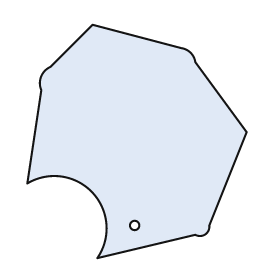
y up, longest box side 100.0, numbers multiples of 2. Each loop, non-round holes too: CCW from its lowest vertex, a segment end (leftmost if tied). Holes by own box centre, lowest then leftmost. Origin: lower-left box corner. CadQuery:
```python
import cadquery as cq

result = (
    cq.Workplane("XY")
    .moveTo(30.0, 0.0)
    .lineTo(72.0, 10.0)
    .threePointArc((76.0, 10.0), (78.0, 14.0))
    .lineTo(94.0, 54.0)
    .lineTo(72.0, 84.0)
    .threePointArc((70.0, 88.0), (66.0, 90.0))
    .lineTo(28.0, 100.0)
    .lineTo(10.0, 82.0)
    .threePointArc((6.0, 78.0), (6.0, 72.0))
    .lineTo(0.0, 32.0)
    .threePointArc((28.0, 28.0), (30.0, 0.0))
    .close()
    .moveTo(46.0, 14.0)
    .circle(2.0)
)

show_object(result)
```